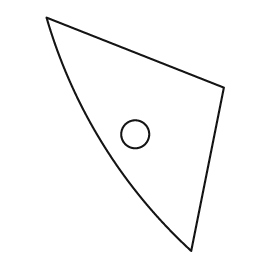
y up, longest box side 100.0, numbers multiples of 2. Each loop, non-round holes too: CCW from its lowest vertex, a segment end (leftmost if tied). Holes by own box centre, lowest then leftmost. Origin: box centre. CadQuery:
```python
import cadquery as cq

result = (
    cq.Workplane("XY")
    .moveTo(24.0, -50.0)
    .lineTo(38.0, 20.0)
    .lineTo(-38.0, 50.0)
    .threePointArc((-14.0, -4.0), (24.0, -50.0))
    .close()
    .moveTo(0.0, 0.0)
    .circle(6.0)
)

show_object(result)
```